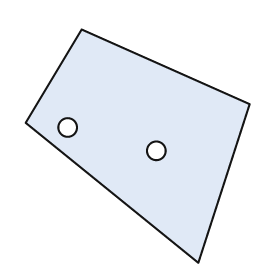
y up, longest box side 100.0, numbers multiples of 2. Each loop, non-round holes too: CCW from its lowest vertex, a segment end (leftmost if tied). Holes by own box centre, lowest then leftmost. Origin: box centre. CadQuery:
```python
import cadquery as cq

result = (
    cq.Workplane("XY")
    .moveTo(26.0, -50.0)
    .lineTo(48.0, 18.0)
    .lineTo(-24.0, 50.0)
    .lineTo(-48.0, 10.0)
    .close()
    .moveTo(8.0, -2.0)
    .circle(4.0)
    .moveTo(-30.0, 8.0)
    .circle(4.0)
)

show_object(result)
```